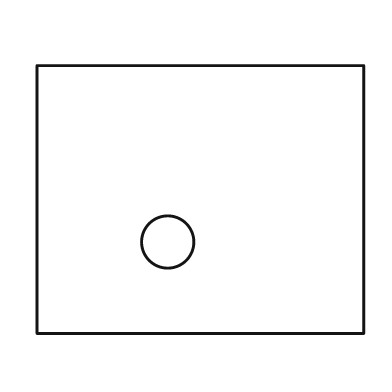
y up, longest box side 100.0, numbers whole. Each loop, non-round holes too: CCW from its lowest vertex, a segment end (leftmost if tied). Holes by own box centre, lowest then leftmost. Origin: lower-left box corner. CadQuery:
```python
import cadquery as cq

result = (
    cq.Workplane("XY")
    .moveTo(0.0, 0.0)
    .lineTo(100.0, 0.0)
    .lineTo(100.0, 82.0)
    .lineTo(0.0, 82.0)
    .close()
    .moveTo(40.0, 28.0)
    .circle(8.0)
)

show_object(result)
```